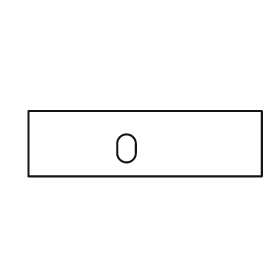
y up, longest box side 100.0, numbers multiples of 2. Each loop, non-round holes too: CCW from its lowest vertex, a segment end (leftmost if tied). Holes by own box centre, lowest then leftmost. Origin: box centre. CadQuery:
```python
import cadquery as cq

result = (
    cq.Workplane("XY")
    .moveTo(-50.0, -14.0)
    .lineTo(50.0, -14.0)
    .lineTo(50.0, 14.0)
    .lineTo(-50.0, 14.0)
    .close()
    .moveTo(-12.0, -4.0)
    .threePointArc((-8.0, -8.0), (-4.0, -4.0))
    .lineTo(-4.0, 0.0)
    .threePointArc((-8.0, 4.0), (-12.0, 0.0))
    .close()
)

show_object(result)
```